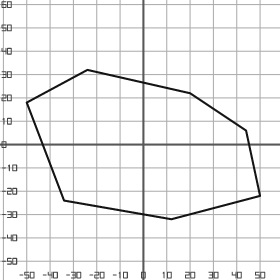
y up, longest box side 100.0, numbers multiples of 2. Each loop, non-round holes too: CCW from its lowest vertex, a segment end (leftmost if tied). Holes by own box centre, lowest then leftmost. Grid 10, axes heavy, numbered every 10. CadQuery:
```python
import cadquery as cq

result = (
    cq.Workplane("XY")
    .moveTo(12.0, -32.0)
    .lineTo(50.0, -22.0)
    .lineTo(44.0, 6.0)
    .lineTo(20.0, 22.0)
    .lineTo(-24.0, 32.0)
    .lineTo(-50.0, 18.0)
    .lineTo(-34.0, -24.0)
    .close()
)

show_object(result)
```